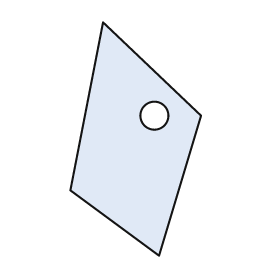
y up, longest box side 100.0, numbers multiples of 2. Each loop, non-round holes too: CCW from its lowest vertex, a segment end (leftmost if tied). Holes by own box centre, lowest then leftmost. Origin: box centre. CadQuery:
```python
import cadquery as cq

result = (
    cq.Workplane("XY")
    .moveTo(10.0, -50.0)
    .lineTo(28.0, 10.0)
    .lineTo(-14.0, 50.0)
    .lineTo(-28.0, -22.0)
    .close()
    .moveTo(8.0, 10.0)
    .circle(6.0)
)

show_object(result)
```